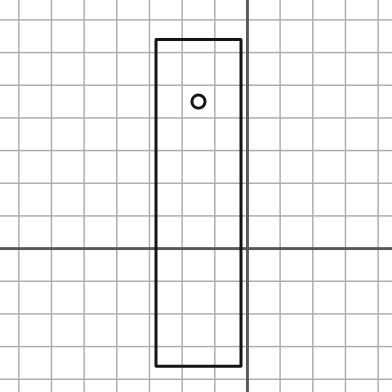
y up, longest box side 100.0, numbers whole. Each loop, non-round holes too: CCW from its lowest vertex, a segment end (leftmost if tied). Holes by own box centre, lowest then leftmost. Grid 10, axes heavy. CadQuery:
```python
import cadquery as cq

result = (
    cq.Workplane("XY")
    .moveTo(-28.0, -36.0)
    .lineTo(-2.0, -36.0)
    .lineTo(-2.0, 64.0)
    .lineTo(-28.0, 64.0)
    .close()
    .moveTo(-15.0, 45.0)
    .circle(2.0)
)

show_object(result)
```